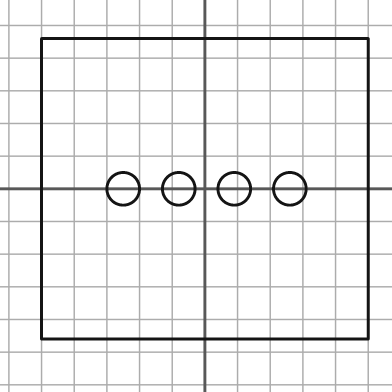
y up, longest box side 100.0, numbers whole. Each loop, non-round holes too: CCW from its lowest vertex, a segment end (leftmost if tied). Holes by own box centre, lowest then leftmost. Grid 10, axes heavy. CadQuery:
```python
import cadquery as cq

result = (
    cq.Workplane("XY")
    .moveTo(-50.0, -46.0)
    .lineTo(50.0, -46.0)
    .lineTo(50.0, 46.0)
    .lineTo(-50.0, 46.0)
    .close()
    .moveTo(-25.0, 0.0)
    .circle(5.0)
    .moveTo(-8.0, 0.0)
    .circle(5.0)
    .moveTo(9.0, 0.0)
    .circle(5.0)
    .moveTo(26.0, 0.0)
    .circle(5.0)
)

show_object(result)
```